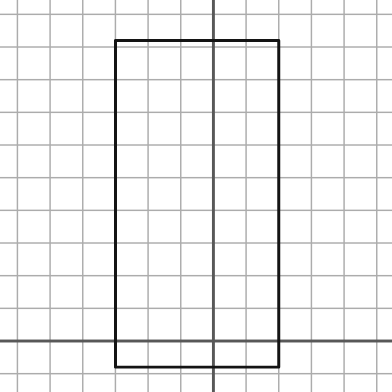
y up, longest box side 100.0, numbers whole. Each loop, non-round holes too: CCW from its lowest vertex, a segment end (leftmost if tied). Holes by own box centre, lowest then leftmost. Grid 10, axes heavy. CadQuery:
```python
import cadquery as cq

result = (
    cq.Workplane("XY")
    .moveTo(-30.0, -8.0)
    .lineTo(20.0, -8.0)
    .lineTo(20.0, 92.0)
    .lineTo(-30.0, 92.0)
    .close()
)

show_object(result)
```